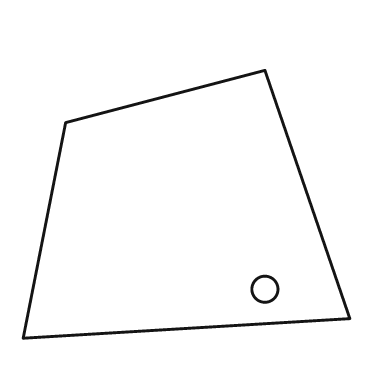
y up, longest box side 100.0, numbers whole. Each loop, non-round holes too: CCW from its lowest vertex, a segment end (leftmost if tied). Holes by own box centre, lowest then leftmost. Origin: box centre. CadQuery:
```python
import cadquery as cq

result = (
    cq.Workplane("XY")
    .moveTo(-50.0, -41.0)
    .lineTo(50.0, -35.0)
    .lineTo(24.0, 41.0)
    .lineTo(-37.0, 25.0)
    .close()
    .moveTo(24.0, -26.0)
    .circle(4.0)
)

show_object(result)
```